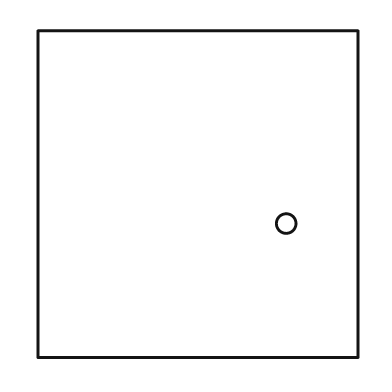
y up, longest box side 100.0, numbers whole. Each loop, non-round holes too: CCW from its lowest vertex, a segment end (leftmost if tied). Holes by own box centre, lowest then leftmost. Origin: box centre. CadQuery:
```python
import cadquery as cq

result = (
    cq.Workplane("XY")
    .moveTo(-49.0, -50.0)
    .lineTo(49.0, -50.0)
    .lineTo(49.0, 50.0)
    .lineTo(-49.0, 50.0)
    .close()
    .moveTo(27.0, -9.0)
    .circle(3.0)
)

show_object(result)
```